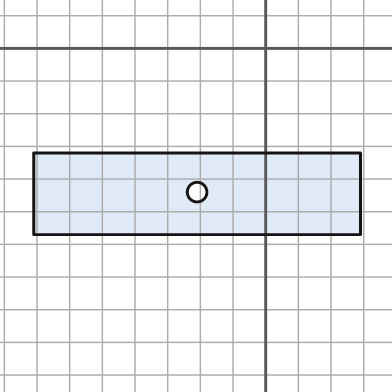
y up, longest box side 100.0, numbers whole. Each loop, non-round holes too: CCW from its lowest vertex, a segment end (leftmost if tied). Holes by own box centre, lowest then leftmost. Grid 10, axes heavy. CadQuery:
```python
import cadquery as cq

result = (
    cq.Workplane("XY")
    .moveTo(-71.0, -57.0)
    .lineTo(29.0, -57.0)
    .lineTo(29.0, -32.0)
    .lineTo(-71.0, -32.0)
    .close()
    .moveTo(-21.0, -44.0)
    .circle(3.0)
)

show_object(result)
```